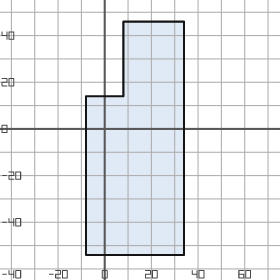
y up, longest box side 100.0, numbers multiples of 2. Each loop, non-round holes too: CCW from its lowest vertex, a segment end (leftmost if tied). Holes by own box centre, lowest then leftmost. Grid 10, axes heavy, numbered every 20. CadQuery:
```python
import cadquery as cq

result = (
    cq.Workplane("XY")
    .moveTo(-8.0, -54.0)
    .lineTo(34.0, -54.0)
    .lineTo(34.0, 46.0)
    .lineTo(8.0, 46.0)
    .lineTo(8.0, 14.0)
    .lineTo(-8.0, 14.0)
    .close()
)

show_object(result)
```